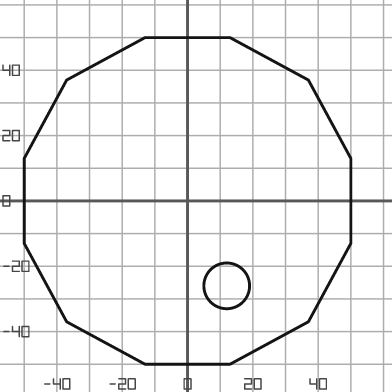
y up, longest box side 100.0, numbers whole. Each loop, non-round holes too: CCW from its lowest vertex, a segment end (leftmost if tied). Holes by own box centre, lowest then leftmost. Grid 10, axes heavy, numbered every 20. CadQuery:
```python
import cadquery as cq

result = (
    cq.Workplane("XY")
    .moveTo(-13.0, -50.0)
    .lineTo(13.0, -50.0)
    .lineTo(37.0, -37.0)
    .lineTo(50.0, -13.0)
    .lineTo(50.0, 13.0)
    .lineTo(37.0, 37.0)
    .lineTo(13.0, 50.0)
    .lineTo(-13.0, 50.0)
    .lineTo(-37.0, 37.0)
    .lineTo(-50.0, 13.0)
    .lineTo(-50.0, -13.0)
    .lineTo(-37.0, -37.0)
    .close()
    .moveTo(12.0, -26.0)
    .circle(7.0)
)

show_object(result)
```